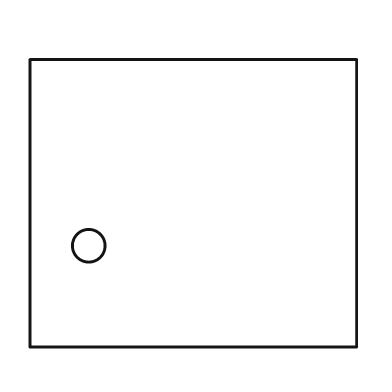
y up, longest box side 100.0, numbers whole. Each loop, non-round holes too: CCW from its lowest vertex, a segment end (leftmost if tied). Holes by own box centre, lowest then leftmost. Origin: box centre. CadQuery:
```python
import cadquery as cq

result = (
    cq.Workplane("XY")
    .moveTo(-50.0, -44.0)
    .lineTo(50.0, -44.0)
    .lineTo(50.0, 44.0)
    .lineTo(-50.0, 44.0)
    .close()
    .moveTo(-32.0, -13.0)
    .circle(5.0)
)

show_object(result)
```